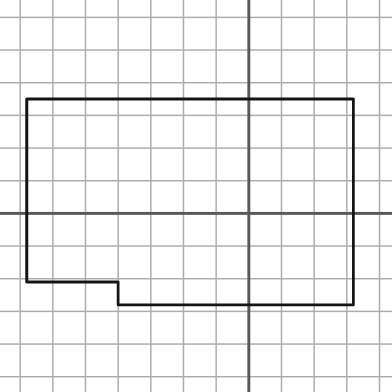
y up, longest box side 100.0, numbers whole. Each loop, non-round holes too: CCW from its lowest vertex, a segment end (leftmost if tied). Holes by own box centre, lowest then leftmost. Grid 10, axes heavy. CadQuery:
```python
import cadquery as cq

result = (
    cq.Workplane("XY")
    .moveTo(-40.0, -28.0)
    .lineTo(32.0, -28.0)
    .lineTo(32.0, 35.0)
    .lineTo(-68.0, 35.0)
    .lineTo(-68.0, -21.0)
    .lineTo(-40.0, -21.0)
    .close()
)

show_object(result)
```